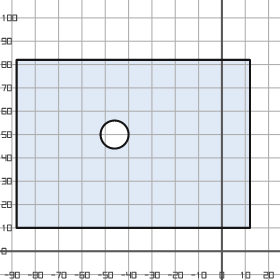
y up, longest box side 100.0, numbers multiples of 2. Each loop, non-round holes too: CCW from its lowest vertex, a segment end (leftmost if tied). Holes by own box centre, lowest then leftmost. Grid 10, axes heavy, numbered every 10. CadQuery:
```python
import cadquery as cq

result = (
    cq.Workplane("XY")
    .moveTo(-88.0, 10.0)
    .lineTo(12.0, 10.0)
    .lineTo(12.0, 82.0)
    .lineTo(-88.0, 82.0)
    .close()
    .moveTo(-46.0, 50.0)
    .circle(6.0)
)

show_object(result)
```